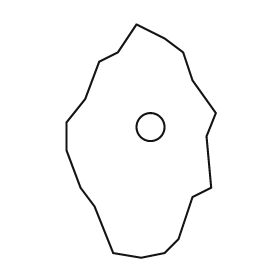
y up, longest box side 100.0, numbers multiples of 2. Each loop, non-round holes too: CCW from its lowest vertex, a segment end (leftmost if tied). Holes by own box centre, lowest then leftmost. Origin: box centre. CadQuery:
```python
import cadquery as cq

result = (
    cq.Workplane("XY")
    .moveTo(0.0, -50.0)
    .lineTo(10.0, -48.0)
    .lineTo(16.0, -42.0)
    .lineTo(22.0, -24.0)
    .lineTo(30.0, -20.0)
    .lineTo(28.0, 2.0)
    .lineTo(32.0, 12.0)
    .lineTo(22.0, 26.0)
    .lineTo(18.0, 38.0)
    .lineTo(10.0, 44.0)
    .lineTo(-2.0, 50.0)
    .lineTo(-10.0, 38.0)
    .lineTo(-18.0, 34.0)
    .lineTo(-24.0, 18.0)
    .lineTo(-32.0, 8.0)
    .lineTo(-32.0, -4.0)
    .lineTo(-26.0, -20.0)
    .lineTo(-20.0, -28.0)
    .lineTo(-12.0, -48.0)
    .close()
    .moveTo(4.0, 6.0)
    .circle(6.0)
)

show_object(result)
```